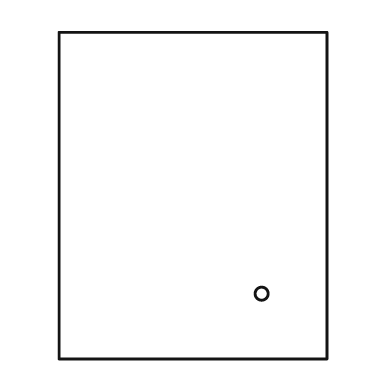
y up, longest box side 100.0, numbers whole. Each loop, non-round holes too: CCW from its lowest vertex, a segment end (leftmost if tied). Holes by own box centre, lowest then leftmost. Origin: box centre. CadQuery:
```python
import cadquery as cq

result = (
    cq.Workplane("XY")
    .moveTo(-41.0, -50.0)
    .lineTo(41.0, -50.0)
    .lineTo(41.0, 50.0)
    .lineTo(-41.0, 50.0)
    .close()
    .moveTo(21.0, -30.0)
    .circle(2.0)
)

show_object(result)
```